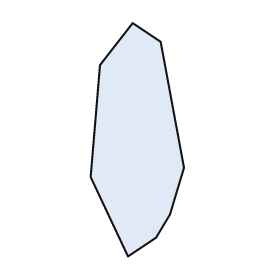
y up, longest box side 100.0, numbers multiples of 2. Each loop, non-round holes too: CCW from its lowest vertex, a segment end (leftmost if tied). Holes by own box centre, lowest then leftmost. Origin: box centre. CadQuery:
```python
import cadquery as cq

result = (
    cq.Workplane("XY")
    .moveTo(-4.0, -50.0)
    .lineTo(8.0, -42.0)
    .lineTo(14.0, -32.0)
    .lineTo(20.0, -12.0)
    .lineTo(10.0, 42.0)
    .lineTo(-2.0, 50.0)
    .lineTo(-16.0, 32.0)
    .lineTo(-20.0, -16.0)
    .close()
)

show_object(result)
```